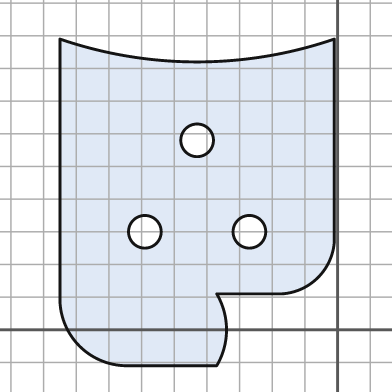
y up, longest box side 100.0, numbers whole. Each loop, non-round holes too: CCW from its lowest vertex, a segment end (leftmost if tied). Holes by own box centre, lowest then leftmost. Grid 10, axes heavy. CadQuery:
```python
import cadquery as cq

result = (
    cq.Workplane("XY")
    .moveTo(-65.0, -11.0)
    .lineTo(-37.0, -11.0)
    .threePointArc((-34.0, 0.0), (-37.0, 11.0))
    .lineTo(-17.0, 11.0)
    .threePointArc((-6.0, 16.0), (-1.0, 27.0))
    .lineTo(-1.0, 89.0)
    .threePointArc((-43.0, 82.0), (-85.0, 89.0))
    .lineTo(-85.0, 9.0)
    .threePointArc((-79.0, -5.0), (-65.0, -11.0))
    .close()
    .moveTo(-59.0, 30.0)
    .circle(5.0)
    .moveTo(-27.0, 30.0)
    .circle(5.0)
    .moveTo(-43.0, 58.0)
    .circle(5.0)
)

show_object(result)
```